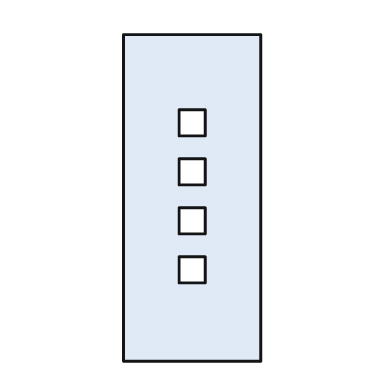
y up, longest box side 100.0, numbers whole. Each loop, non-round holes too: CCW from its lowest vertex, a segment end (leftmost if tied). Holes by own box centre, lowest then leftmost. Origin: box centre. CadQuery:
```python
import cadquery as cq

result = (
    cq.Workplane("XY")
    .moveTo(-21.0, -50.0)
    .lineTo(21.0, -50.0)
    .lineTo(21.0, 50.0)
    .lineTo(-21.0, 50.0)
    .close()
    .moveTo(-4.0, -26.0)
    .lineTo(4.0, -26.0)
    .lineTo(4.0, -18.0)
    .lineTo(-4.0, -18.0)
    .close()
    .moveTo(-4.0, -11.0)
    .lineTo(4.0, -11.0)
    .lineTo(4.0, -3.0)
    .lineTo(-4.0, -3.0)
    .close()
    .moveTo(-4.0, 4.0)
    .lineTo(4.0, 4.0)
    .lineTo(4.0, 12.0)
    .lineTo(-4.0, 12.0)
    .close()
    .moveTo(-4.0, 19.0)
    .lineTo(4.0, 19.0)
    .lineTo(4.0, 27.0)
    .lineTo(-4.0, 27.0)
    .close()
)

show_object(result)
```